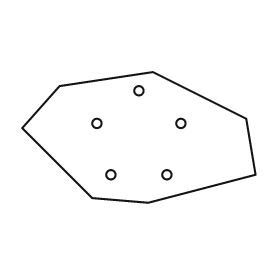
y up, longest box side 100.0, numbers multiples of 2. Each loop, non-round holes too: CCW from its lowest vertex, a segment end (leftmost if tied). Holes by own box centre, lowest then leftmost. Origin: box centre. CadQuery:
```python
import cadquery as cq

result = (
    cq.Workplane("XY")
    .moveTo(4.0, -28.0)
    .lineTo(50.0, -16.0)
    .lineTo(46.0, 8.0)
    .lineTo(6.0, 28.0)
    .lineTo(-34.0, 22.0)
    .lineTo(-50.0, 4.0)
    .lineTo(-20.0, -26.0)
    .close()
    .moveTo(-12.0, -16.0)
    .circle(2.0)
    .moveTo(12.0, -16.0)
    .circle(2.0)
    .moveTo(-18.0, 6.0)
    .circle(2.0)
    .moveTo(18.0, 6.0)
    .circle(2.0)
    .moveTo(0.0, 20.0)
    .circle(2.0)
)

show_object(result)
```